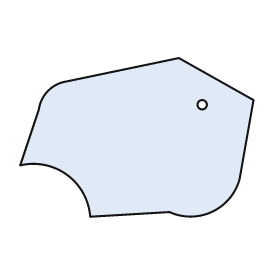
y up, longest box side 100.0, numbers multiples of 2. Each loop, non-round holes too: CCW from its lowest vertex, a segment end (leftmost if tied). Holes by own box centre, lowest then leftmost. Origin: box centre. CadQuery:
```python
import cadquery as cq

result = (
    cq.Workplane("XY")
    .moveTo(-20.0, -34.0)
    .lineTo(14.0, -32.0)
    .threePointArc((32.0, -32.0), (44.0, -18.0))
    .lineTo(50.0, 16.0)
    .lineTo(18.0, 34.0)
    .lineTo(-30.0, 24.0)
    .threePointArc((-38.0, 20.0), (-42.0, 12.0))
    .lineTo(-50.0, -12.0)
    .threePointArc((-30.0, -16.0), (-20.0, -34.0))
    .close()
    .moveTo(28.0, 14.0)
    .circle(2.0)
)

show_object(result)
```